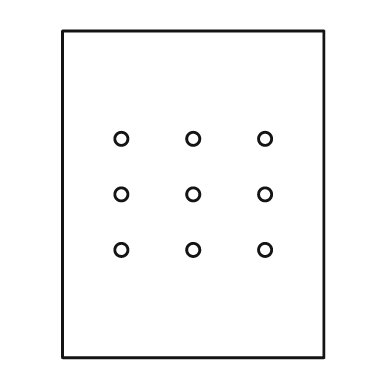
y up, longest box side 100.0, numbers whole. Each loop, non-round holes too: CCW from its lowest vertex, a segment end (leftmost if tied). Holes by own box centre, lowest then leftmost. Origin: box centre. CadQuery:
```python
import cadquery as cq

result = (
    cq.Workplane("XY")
    .moveTo(-40.0, -50.0)
    .lineTo(40.0, -50.0)
    .lineTo(40.0, 50.0)
    .lineTo(-40.0, 50.0)
    .close()
    .moveTo(-22.0, -17.0)
    .circle(2.0)
    .moveTo(0.0, -17.0)
    .circle(2.0)
    .moveTo(22.0, -17.0)
    .circle(2.0)
    .moveTo(-22.0, 0.0)
    .circle(2.0)
    .moveTo(0.0, 0.0)
    .circle(2.0)
    .moveTo(22.0, 0.0)
    .circle(2.0)
    .moveTo(-22.0, 17.0)
    .circle(2.0)
    .moveTo(0.0, 17.0)
    .circle(2.0)
    .moveTo(22.0, 17.0)
    .circle(2.0)
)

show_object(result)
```